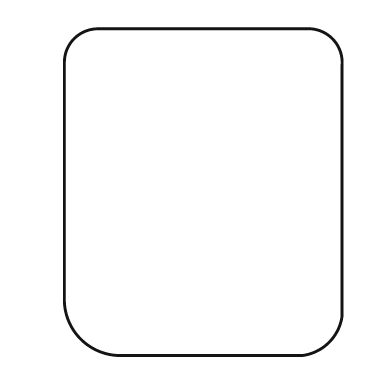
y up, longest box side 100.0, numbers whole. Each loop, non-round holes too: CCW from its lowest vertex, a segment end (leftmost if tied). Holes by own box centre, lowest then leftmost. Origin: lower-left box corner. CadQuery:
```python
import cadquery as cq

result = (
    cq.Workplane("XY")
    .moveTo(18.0, 0.0)
    .lineTo(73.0, 0.0)
    .threePointArc((81.0, 4.0), (85.0, 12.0))
    .lineTo(85.0, 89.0)
    .threePointArc((82.0, 97.0), (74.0, 100.0))
    .lineTo(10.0, 100.0)
    .threePointArc((3.0, 97.0), (0.0, 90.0))
    .lineTo(0.0, 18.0)
    .threePointArc((5.0, 5.0), (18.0, 0.0))
    .close()
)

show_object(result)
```